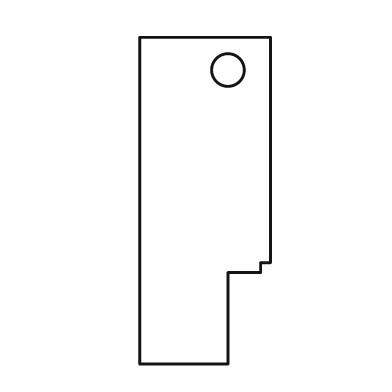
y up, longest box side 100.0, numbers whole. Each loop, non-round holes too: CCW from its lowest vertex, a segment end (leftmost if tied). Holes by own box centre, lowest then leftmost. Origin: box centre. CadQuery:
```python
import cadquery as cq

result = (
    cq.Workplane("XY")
    .moveTo(-20.0, -50.0)
    .lineTo(7.0, -50.0)
    .lineTo(7.0, -22.0)
    .lineTo(17.0, -22.0)
    .lineTo(17.0, -19.0)
    .lineTo(20.0, -19.0)
    .lineTo(20.0, 50.0)
    .lineTo(-20.0, 50.0)
    .close()
    .moveTo(7.0, 40.0)
    .circle(5.0)
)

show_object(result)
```